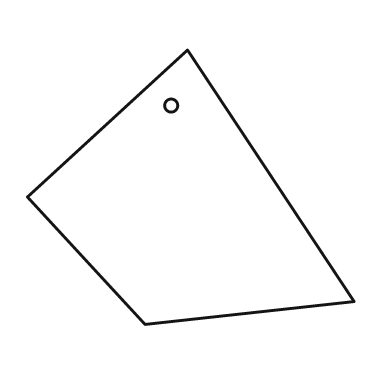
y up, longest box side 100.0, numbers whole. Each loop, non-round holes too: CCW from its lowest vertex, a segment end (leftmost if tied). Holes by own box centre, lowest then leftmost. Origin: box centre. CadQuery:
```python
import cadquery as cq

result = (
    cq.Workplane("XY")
    .moveTo(-14.0, -42.0)
    .lineTo(50.0, -35.0)
    .lineTo(-1.0, 42.0)
    .lineTo(-50.0, -3.0)
    .close()
    .moveTo(-6.0, 25.0)
    .circle(2.0)
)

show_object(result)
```